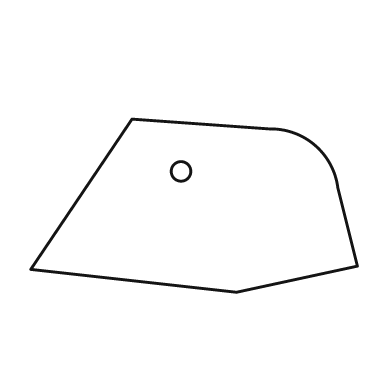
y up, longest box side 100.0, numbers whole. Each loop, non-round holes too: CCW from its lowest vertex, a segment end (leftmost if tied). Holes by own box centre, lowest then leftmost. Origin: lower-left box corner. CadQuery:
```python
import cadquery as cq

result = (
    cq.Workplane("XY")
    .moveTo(63.0, 0.0)
    .lineTo(100.0, 8.0)
    .lineTo(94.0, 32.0)
    .threePointArc((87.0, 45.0), (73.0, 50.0))
    .lineTo(31.0, 53.0)
    .lineTo(0.0, 7.0)
    .close()
    .moveTo(46.0, 37.0)
    .circle(3.0)
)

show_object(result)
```